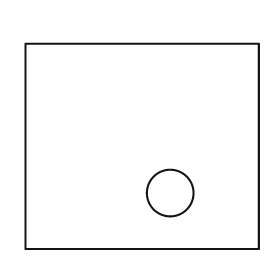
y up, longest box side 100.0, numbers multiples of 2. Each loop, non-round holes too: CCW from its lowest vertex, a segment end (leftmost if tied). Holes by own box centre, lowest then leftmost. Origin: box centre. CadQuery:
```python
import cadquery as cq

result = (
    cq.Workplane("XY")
    .moveTo(-50.0, -44.0)
    .lineTo(50.0, -44.0)
    .lineTo(50.0, 44.0)
    .lineTo(-50.0, 44.0)
    .close()
    .moveTo(12.0, -20.0)
    .circle(10.0)
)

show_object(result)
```